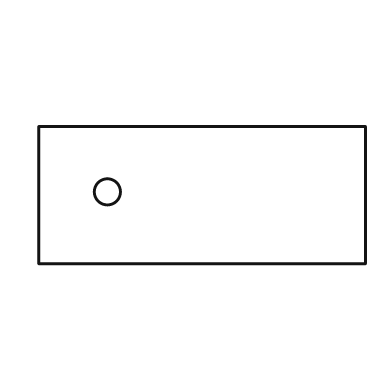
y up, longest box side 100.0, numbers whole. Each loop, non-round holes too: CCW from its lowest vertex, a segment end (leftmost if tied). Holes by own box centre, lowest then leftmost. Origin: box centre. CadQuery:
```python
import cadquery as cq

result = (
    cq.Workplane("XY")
    .moveTo(-50.0, -21.0)
    .lineTo(50.0, -21.0)
    .lineTo(50.0, 21.0)
    .lineTo(-50.0, 21.0)
    .close()
    .moveTo(-29.0, 1.0)
    .circle(4.0)
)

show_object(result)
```